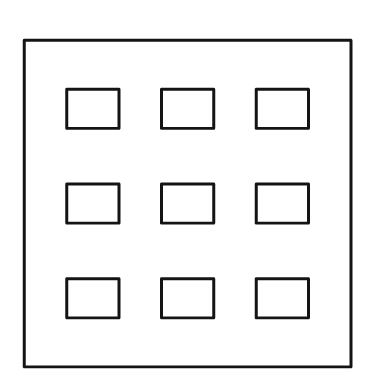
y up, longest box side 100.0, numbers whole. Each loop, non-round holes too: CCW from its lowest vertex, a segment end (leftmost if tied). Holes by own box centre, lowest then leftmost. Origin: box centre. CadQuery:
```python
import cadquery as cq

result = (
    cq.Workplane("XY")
    .moveTo(-50.0, -50.0)
    .lineTo(50.0, -50.0)
    .lineTo(50.0, 50.0)
    .lineTo(-50.0, 50.0)
    .close()
    .moveTo(-37.0, -35.0)
    .lineTo(-21.0, -35.0)
    .lineTo(-21.0, -23.0)
    .lineTo(-37.0, -23.0)
    .close()
    .moveTo(-8.0, -35.0)
    .lineTo(8.0, -35.0)
    .lineTo(8.0, -23.0)
    .lineTo(-8.0, -23.0)
    .close()
    .moveTo(21.0, -35.0)
    .lineTo(37.0, -35.0)
    .lineTo(37.0, -23.0)
    .lineTo(21.0, -23.0)
    .close()
    .moveTo(-37.0, -6.0)
    .lineTo(-21.0, -6.0)
    .lineTo(-21.0, 6.0)
    .lineTo(-37.0, 6.0)
    .close()
    .moveTo(-8.0, -6.0)
    .lineTo(8.0, -6.0)
    .lineTo(8.0, 6.0)
    .lineTo(-8.0, 6.0)
    .close()
    .moveTo(21.0, -6.0)
    .lineTo(37.0, -6.0)
    .lineTo(37.0, 6.0)
    .lineTo(21.0, 6.0)
    .close()
    .moveTo(-37.0, 23.0)
    .lineTo(-21.0, 23.0)
    .lineTo(-21.0, 35.0)
    .lineTo(-37.0, 35.0)
    .close()
    .moveTo(-8.0, 23.0)
    .lineTo(8.0, 23.0)
    .lineTo(8.0, 35.0)
    .lineTo(-8.0, 35.0)
    .close()
    .moveTo(21.0, 23.0)
    .lineTo(37.0, 23.0)
    .lineTo(37.0, 35.0)
    .lineTo(21.0, 35.0)
    .close()
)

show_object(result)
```